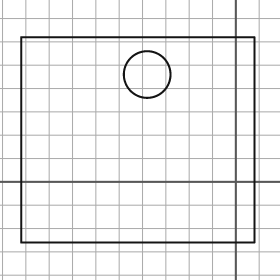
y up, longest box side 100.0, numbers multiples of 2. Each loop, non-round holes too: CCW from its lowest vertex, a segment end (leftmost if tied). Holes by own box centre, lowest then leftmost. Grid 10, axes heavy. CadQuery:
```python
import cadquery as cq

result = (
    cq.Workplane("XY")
    .moveTo(-92.0, -26.0)
    .lineTo(8.0, -26.0)
    .lineTo(8.0, 62.0)
    .lineTo(-92.0, 62.0)
    .close()
    .moveTo(-38.0, 46.0)
    .circle(10.0)
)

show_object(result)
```